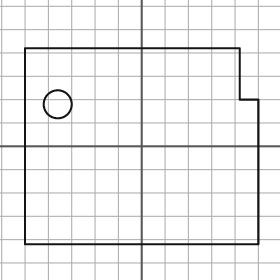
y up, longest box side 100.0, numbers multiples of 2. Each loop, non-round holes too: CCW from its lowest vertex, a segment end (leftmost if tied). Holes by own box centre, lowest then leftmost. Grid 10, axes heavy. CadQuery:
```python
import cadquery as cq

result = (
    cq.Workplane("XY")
    .moveTo(-50.0, -42.0)
    .lineTo(50.0, -42.0)
    .lineTo(50.0, 20.0)
    .lineTo(42.0, 20.0)
    .lineTo(42.0, 42.0)
    .lineTo(-50.0, 42.0)
    .close()
    .moveTo(-36.0, 18.0)
    .circle(6.0)
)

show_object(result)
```